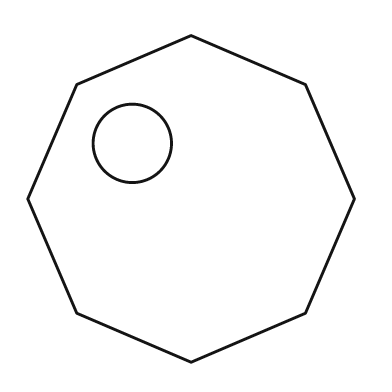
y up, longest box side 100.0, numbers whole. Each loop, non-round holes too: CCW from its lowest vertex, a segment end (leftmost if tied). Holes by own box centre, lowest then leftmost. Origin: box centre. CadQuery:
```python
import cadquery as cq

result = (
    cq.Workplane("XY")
    .moveTo(0.0, -50.0)
    .lineTo(35.0, -35.0)
    .lineTo(50.0, 0.0)
    .lineTo(35.0, 35.0)
    .lineTo(0.0, 50.0)
    .lineTo(-35.0, 35.0)
    .lineTo(-50.0, 0.0)
    .lineTo(-35.0, -35.0)
    .close()
    .moveTo(-18.0, 17.0)
    .circle(12.0)
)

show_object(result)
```